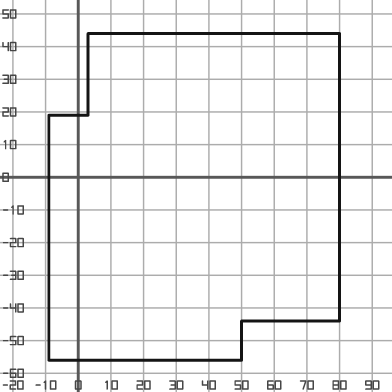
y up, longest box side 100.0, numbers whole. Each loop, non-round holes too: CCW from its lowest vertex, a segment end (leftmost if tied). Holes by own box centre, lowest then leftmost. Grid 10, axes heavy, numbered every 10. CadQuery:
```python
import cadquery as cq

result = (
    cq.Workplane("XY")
    .moveTo(-9.0, -56.0)
    .lineTo(50.0, -56.0)
    .lineTo(50.0, -44.0)
    .lineTo(80.0, -44.0)
    .lineTo(80.0, 44.0)
    .lineTo(3.0, 44.0)
    .lineTo(3.0, 19.0)
    .lineTo(-9.0, 19.0)
    .close()
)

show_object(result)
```